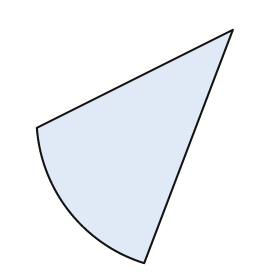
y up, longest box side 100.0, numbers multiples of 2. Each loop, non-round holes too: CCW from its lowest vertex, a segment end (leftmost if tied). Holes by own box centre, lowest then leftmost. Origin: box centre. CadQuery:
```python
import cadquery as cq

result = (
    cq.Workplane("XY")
    .moveTo(4.0, -50.0)
    .lineTo(42.0, 50.0)
    .lineTo(-42.0, 8.0)
    .threePointArc((-28.0, -28.0), (4.0, -50.0))
    .close()
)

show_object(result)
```